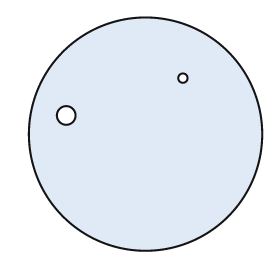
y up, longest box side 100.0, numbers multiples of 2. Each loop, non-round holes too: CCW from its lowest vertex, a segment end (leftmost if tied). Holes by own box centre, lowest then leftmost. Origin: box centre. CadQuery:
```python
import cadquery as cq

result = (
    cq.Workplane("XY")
    .moveTo(0.0, 0.0)
    .circle(50.0)
    .moveTo(-34.0, 8.0)
    .circle(4.0)
    .moveTo(16.0, 24.0)
    .circle(2.0)
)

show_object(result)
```